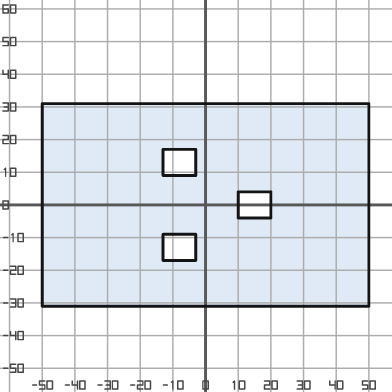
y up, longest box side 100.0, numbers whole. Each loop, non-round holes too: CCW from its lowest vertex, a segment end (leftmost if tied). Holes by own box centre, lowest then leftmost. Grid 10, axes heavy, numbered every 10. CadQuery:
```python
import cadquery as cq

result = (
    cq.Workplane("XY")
    .moveTo(-50.0, -31.0)
    .lineTo(50.0, -31.0)
    .lineTo(50.0, 31.0)
    .lineTo(-50.0, 31.0)
    .close()
    .moveTo(-13.0, -17.0)
    .lineTo(-3.0, -17.0)
    .lineTo(-3.0, -9.0)
    .lineTo(-13.0, -9.0)
    .close()
    .moveTo(10.0, -4.0)
    .lineTo(20.0, -4.0)
    .lineTo(20.0, 4.0)
    .lineTo(10.0, 4.0)
    .close()
    .moveTo(-13.0, 9.0)
    .lineTo(-3.0, 9.0)
    .lineTo(-3.0, 17.0)
    .lineTo(-13.0, 17.0)
    .close()
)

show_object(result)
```